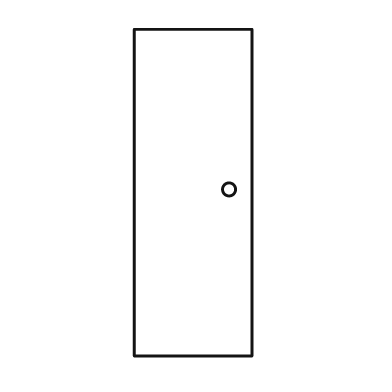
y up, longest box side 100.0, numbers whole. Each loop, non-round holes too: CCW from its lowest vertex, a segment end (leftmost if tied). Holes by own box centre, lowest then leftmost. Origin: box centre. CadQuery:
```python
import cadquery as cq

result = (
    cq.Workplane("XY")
    .moveTo(-18.0, -50.0)
    .lineTo(18.0, -50.0)
    .lineTo(18.0, 50.0)
    .lineTo(-18.0, 50.0)
    .close()
    .moveTo(11.0, 1.0)
    .circle(2.0)
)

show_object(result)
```